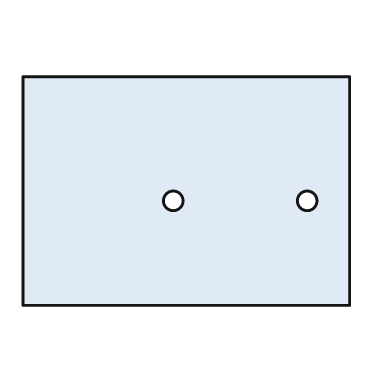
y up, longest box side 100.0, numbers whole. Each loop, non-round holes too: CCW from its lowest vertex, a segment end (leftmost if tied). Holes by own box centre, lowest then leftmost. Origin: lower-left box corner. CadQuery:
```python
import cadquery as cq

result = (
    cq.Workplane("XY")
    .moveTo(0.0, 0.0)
    .lineTo(100.0, 0.0)
    .lineTo(100.0, 70.0)
    .lineTo(0.0, 70.0)
    .close()
    .moveTo(46.0, 32.0)
    .circle(3.0)
    .moveTo(87.0, 32.0)
    .circle(3.0)
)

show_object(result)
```